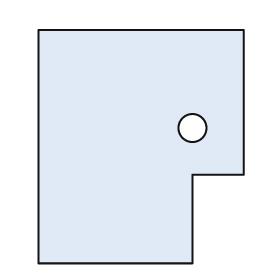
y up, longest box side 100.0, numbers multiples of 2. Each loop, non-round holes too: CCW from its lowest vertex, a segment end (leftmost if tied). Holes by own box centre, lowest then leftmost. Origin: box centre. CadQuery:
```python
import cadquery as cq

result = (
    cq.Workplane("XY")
    .moveTo(-44.0, -50.0)
    .lineTo(22.0, -50.0)
    .lineTo(22.0, -12.0)
    .lineTo(44.0, -12.0)
    .lineTo(44.0, 50.0)
    .lineTo(-44.0, 50.0)
    .close()
    .moveTo(22.0, 8.0)
    .circle(6.0)
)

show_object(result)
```